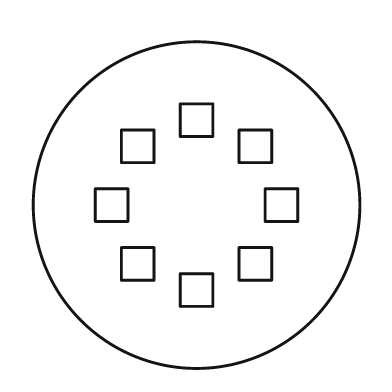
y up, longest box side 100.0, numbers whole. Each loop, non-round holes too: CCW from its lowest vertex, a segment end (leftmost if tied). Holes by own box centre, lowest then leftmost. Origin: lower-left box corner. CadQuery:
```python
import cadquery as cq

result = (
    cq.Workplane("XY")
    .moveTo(50.0, 50.0)
    .circle(50.0)
    .moveTo(45.0, 19.0)
    .lineTo(55.0, 19.0)
    .lineTo(55.0, 29.0)
    .lineTo(45.0, 29.0)
    .close()
    .moveTo(27.0, 27.0)
    .lineTo(37.0, 27.0)
    .lineTo(37.0, 37.0)
    .lineTo(27.0, 37.0)
    .close()
    .moveTo(63.0, 27.0)
    .lineTo(73.0, 27.0)
    .lineTo(73.0, 37.0)
    .lineTo(63.0, 37.0)
    .close()
    .moveTo(19.0, 45.0)
    .lineTo(29.0, 45.0)
    .lineTo(29.0, 55.0)
    .lineTo(19.0, 55.0)
    .close()
    .moveTo(71.0, 45.0)
    .lineTo(81.0, 45.0)
    .lineTo(81.0, 55.0)
    .lineTo(71.0, 55.0)
    .close()
    .moveTo(27.0, 63.0)
    .lineTo(37.0, 63.0)
    .lineTo(37.0, 73.0)
    .lineTo(27.0, 73.0)
    .close()
    .moveTo(63.0, 63.0)
    .lineTo(73.0, 63.0)
    .lineTo(73.0, 73.0)
    .lineTo(63.0, 73.0)
    .close()
    .moveTo(45.0, 71.0)
    .lineTo(55.0, 71.0)
    .lineTo(55.0, 81.0)
    .lineTo(45.0, 81.0)
    .close()
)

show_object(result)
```